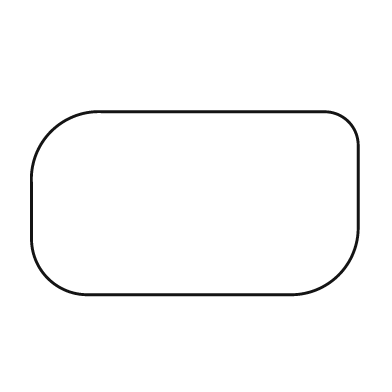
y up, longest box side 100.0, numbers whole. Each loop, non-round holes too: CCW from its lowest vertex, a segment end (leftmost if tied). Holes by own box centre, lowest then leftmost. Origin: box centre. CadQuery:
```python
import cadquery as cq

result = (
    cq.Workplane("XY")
    .moveTo(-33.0, -28.0)
    .lineTo(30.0, -28.0)
    .threePointArc((44.0, -22.0), (50.0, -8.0))
    .lineTo(50.0, 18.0)
    .threePointArc((47.0, 25.0), (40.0, 28.0))
    .lineTo(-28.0, 28.0)
    .threePointArc((-44.0, 22.0), (-50.0, 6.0))
    .lineTo(-50.0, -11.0)
    .threePointArc((-45.0, -23.0), (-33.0, -28.0))
    .close()
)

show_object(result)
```